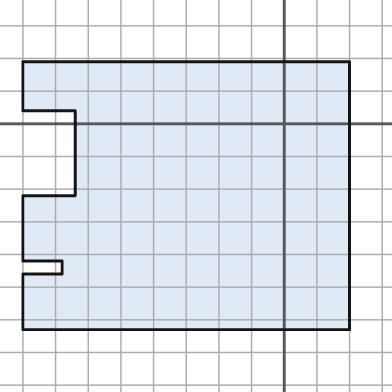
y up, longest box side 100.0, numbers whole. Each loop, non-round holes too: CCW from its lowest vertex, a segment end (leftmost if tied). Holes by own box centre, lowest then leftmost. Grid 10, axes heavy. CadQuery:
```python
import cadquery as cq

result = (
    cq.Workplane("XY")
    .moveTo(-80.0, -63.0)
    .lineTo(20.0, -63.0)
    .lineTo(20.0, 19.0)
    .lineTo(-80.0, 19.0)
    .lineTo(-80.0, 4.0)
    .lineTo(-64.0, 4.0)
    .lineTo(-64.0, -22.0)
    .lineTo(-80.0, -22.0)
    .lineTo(-80.0, -42.0)
    .lineTo(-68.0, -42.0)
    .lineTo(-68.0, -46.0)
    .lineTo(-80.0, -46.0)
    .close()
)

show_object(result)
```